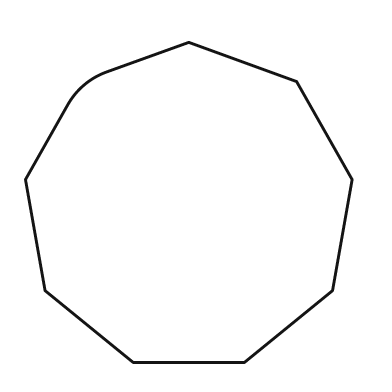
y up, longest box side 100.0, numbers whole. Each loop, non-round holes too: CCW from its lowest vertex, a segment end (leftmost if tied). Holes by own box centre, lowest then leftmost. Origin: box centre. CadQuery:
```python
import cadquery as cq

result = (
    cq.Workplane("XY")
    .moveTo(-17.0, -49.0)
    .lineTo(17.0, -49.0)
    .lineTo(44.0, -27.0)
    .lineTo(50.0, 7.0)
    .lineTo(33.0, 37.0)
    .lineTo(0.0, 49.0)
    .lineTo(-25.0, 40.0)
    .threePointArc((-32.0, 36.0), (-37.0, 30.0))
    .lineTo(-50.0, 7.0)
    .lineTo(-44.0, -27.0)
    .close()
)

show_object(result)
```